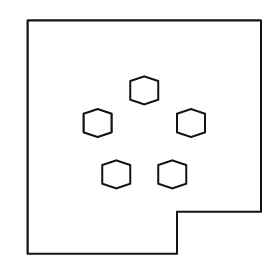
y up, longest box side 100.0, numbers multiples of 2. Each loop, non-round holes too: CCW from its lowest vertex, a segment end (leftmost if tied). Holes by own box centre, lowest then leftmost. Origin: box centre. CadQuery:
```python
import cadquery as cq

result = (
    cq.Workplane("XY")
    .moveTo(-50.0, -50.0)
    .lineTo(14.0, -50.0)
    .lineTo(14.0, -32.0)
    .lineTo(50.0, -32.0)
    .lineTo(50.0, 50.0)
    .lineTo(-50.0, 50.0)
    .close()
    .moveTo(-12.0, -22.0)
    .lineTo(-6.0, -20.0)
    .lineTo(-6.0, -12.0)
    .lineTo(-12.0, -10.0)
    .lineTo(-18.0, -12.0)
    .lineTo(-18.0, -20.0)
    .close()
    .moveTo(12.0, -22.0)
    .lineTo(18.0, -20.0)
    .lineTo(18.0, -12.0)
    .lineTo(12.0, -10.0)
    .lineTo(6.0, -12.0)
    .lineTo(6.0, -20.0)
    .close()
    .moveTo(-20.0, 0.0)
    .lineTo(-14.0, 2.0)
    .lineTo(-14.0, 10.0)
    .lineTo(-20.0, 12.0)
    .lineTo(-26.0, 10.0)
    .lineTo(-26.0, 2.0)
    .close()
    .moveTo(20.0, 0.0)
    .lineTo(26.0, 2.0)
    .lineTo(26.0, 10.0)
    .lineTo(20.0, 12.0)
    .lineTo(14.0, 10.0)
    .lineTo(14.0, 2.0)
    .close()
    .moveTo(0.0, 14.0)
    .lineTo(6.0, 16.0)
    .lineTo(6.0, 24.0)
    .lineTo(0.0, 26.0)
    .lineTo(-6.0, 24.0)
    .lineTo(-6.0, 16.0)
    .close()
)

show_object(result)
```